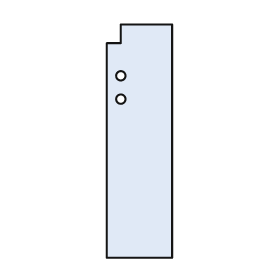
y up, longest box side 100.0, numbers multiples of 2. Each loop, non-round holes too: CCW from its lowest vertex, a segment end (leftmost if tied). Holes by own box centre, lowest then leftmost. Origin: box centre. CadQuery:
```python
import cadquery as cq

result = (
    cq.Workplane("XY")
    .moveTo(-14.0, -50.0)
    .lineTo(14.0, -50.0)
    .lineTo(14.0, 50.0)
    .lineTo(-8.0, 50.0)
    .lineTo(-8.0, 42.0)
    .lineTo(-14.0, 42.0)
    .close()
    .moveTo(-8.0, 18.0)
    .circle(2.0)
    .moveTo(-8.0, 28.0)
    .circle(2.0)
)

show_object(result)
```